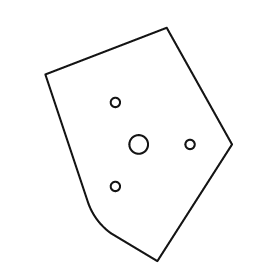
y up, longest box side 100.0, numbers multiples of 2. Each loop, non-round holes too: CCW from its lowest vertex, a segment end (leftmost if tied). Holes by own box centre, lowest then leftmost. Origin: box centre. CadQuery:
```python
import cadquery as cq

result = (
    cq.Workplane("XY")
    .moveTo(8.0, -50.0)
    .lineTo(40.0, 0.0)
    .lineTo(12.0, 50.0)
    .lineTo(-40.0, 30.0)
    .lineTo(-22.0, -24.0)
    .threePointArc((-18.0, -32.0), (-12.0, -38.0))
    .close()
    .moveTo(-10.0, -18.0)
    .circle(2.0)
    .moveTo(0.0, 0.0)
    .circle(4.0)
    .moveTo(22.0, 0.0)
    .circle(2.0)
    .moveTo(-10.0, 18.0)
    .circle(2.0)
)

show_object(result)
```